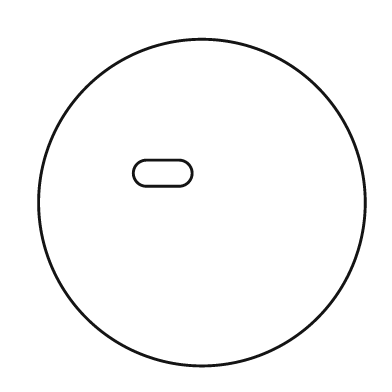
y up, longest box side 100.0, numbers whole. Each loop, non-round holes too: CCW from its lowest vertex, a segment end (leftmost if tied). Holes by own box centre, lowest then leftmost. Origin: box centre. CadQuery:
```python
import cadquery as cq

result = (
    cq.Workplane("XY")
    .moveTo(0.0, 0.0)
    .circle(50.0)
    .moveTo(-17.0, 5.0)
    .lineTo(-7.0, 5.0)
    .threePointArc((-3.0, 9.0), (-7.0, 13.0))
    .lineTo(-17.0, 13.0)
    .threePointArc((-21.0, 9.0), (-17.0, 5.0))
    .close()
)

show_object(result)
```